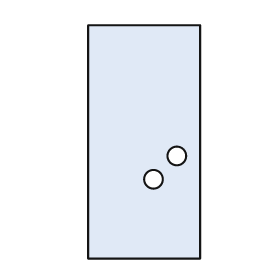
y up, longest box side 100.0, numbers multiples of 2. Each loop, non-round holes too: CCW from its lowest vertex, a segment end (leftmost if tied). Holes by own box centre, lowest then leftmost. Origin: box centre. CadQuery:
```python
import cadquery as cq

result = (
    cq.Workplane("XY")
    .moveTo(-24.0, -50.0)
    .lineTo(24.0, -50.0)
    .lineTo(24.0, 50.0)
    .lineTo(-24.0, 50.0)
    .close()
    .moveTo(4.0, -16.0)
    .circle(4.0)
    .moveTo(14.0, -6.0)
    .circle(4.0)
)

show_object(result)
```